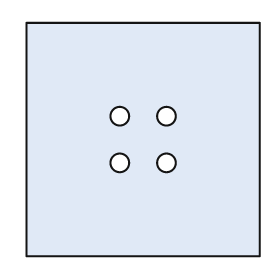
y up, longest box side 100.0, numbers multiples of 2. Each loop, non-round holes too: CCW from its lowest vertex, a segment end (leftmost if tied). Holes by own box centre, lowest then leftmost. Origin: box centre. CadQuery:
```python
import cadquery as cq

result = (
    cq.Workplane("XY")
    .moveTo(-50.0, -50.0)
    .lineTo(50.0, -50.0)
    .lineTo(50.0, 50.0)
    .lineTo(-50.0, 50.0)
    .close()
    .moveTo(-10.0, -10.0)
    .circle(4.0)
    .moveTo(10.0, -10.0)
    .circle(4.0)
    .moveTo(-10.0, 10.0)
    .circle(4.0)
    .moveTo(10.0, 10.0)
    .circle(4.0)
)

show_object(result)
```